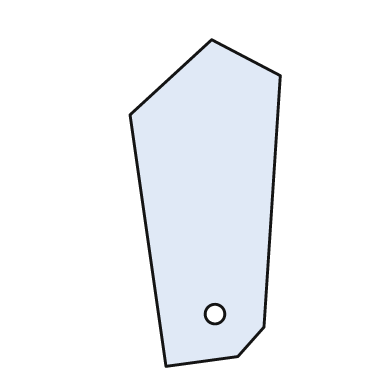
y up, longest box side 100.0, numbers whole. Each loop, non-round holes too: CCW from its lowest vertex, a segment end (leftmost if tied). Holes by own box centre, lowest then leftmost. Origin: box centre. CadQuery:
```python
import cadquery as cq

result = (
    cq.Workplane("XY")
    .moveTo(-12.0, -50.0)
    .lineTo(10.0, -47.0)
    .lineTo(18.0, -38.0)
    .lineTo(23.0, 39.0)
    .lineTo(2.0, 50.0)
    .lineTo(-23.0, 27.0)
    .close()
    .moveTo(3.0, -34.0)
    .circle(3.0)
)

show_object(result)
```